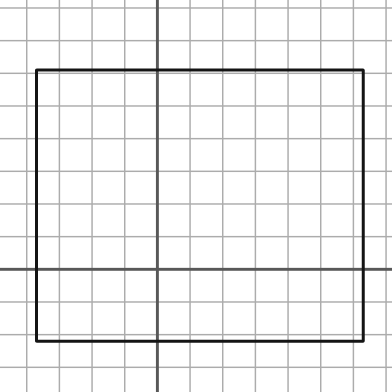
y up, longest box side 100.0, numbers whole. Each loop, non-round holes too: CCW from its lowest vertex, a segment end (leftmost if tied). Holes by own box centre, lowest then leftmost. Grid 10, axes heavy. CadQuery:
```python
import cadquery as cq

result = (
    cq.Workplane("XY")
    .moveTo(-37.0, -22.0)
    .lineTo(63.0, -22.0)
    .lineTo(63.0, 61.0)
    .lineTo(-37.0, 61.0)
    .close()
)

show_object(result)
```